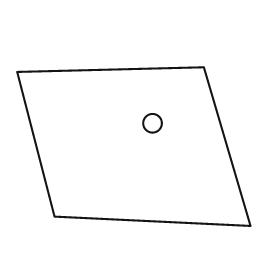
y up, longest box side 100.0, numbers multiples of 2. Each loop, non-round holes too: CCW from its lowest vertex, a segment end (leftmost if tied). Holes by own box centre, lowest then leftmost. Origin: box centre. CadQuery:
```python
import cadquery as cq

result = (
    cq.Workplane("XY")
    .moveTo(50.0, -34.0)
    .lineTo(30.0, 34.0)
    .lineTo(-50.0, 32.0)
    .lineTo(-34.0, -30.0)
    .close()
    .moveTo(8.0, 10.0)
    .circle(4.0)
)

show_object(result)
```